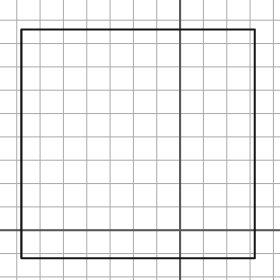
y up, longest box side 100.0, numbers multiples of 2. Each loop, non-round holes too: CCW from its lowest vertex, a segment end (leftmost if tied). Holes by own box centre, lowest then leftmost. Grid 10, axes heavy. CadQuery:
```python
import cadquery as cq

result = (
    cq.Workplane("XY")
    .moveTo(-68.0, -12.0)
    .lineTo(32.0, -12.0)
    .lineTo(32.0, 86.0)
    .lineTo(-68.0, 86.0)
    .close()
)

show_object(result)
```